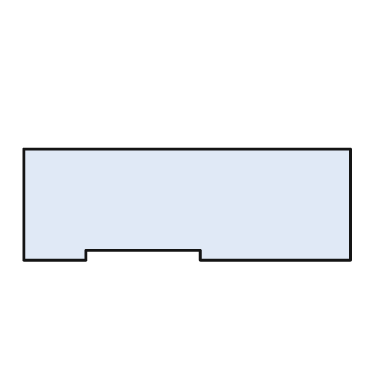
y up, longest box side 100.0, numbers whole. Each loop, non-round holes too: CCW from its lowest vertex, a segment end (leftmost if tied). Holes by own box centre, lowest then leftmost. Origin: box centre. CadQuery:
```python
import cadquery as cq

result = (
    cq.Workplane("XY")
    .moveTo(-50.0, -17.0)
    .lineTo(-31.0, -17.0)
    .lineTo(-31.0, -14.0)
    .lineTo(4.0, -14.0)
    .lineTo(4.0, -17.0)
    .lineTo(50.0, -17.0)
    .lineTo(50.0, 17.0)
    .lineTo(-50.0, 17.0)
    .close()
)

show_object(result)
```